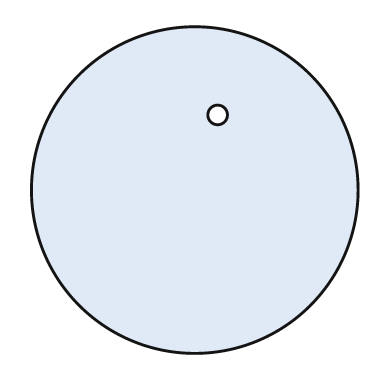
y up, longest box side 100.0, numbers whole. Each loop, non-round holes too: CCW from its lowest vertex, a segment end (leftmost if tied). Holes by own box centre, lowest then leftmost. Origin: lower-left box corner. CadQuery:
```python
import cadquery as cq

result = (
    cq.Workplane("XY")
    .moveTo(50.0, 50.0)
    .circle(50.0)
    .moveTo(57.0, 73.0)
    .circle(3.0)
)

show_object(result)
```